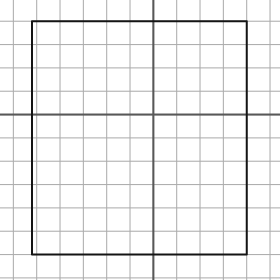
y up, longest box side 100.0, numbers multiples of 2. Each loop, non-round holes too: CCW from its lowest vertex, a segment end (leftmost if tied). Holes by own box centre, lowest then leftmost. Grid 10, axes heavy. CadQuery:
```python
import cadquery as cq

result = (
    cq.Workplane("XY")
    .moveTo(-52.0, -60.0)
    .lineTo(40.0, -60.0)
    .lineTo(40.0, 40.0)
    .lineTo(-52.0, 40.0)
    .close()
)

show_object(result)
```